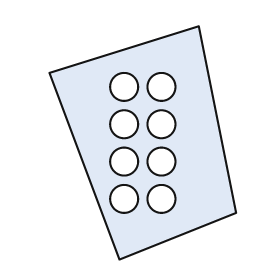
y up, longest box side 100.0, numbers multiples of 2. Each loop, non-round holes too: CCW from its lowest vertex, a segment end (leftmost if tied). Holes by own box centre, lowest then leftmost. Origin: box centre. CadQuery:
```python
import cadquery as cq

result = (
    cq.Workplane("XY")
    .moveTo(-10.0, -50.0)
    .lineTo(40.0, -30.0)
    .lineTo(24.0, 50.0)
    .lineTo(-40.0, 30.0)
    .close()
    .moveTo(-8.0, -24.0)
    .circle(6.0)
    .moveTo(8.0, -24.0)
    .circle(6.0)
    .moveTo(-8.0, -8.0)
    .circle(6.0)
    .moveTo(8.0, -8.0)
    .circle(6.0)
    .moveTo(-8.0, 8.0)
    .circle(6.0)
    .moveTo(8.0, 8.0)
    .circle(6.0)
    .moveTo(-8.0, 24.0)
    .circle(6.0)
    .moveTo(8.0, 24.0)
    .circle(6.0)
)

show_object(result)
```